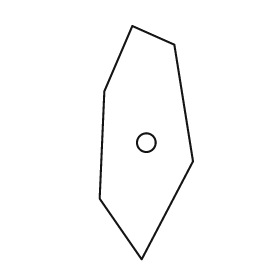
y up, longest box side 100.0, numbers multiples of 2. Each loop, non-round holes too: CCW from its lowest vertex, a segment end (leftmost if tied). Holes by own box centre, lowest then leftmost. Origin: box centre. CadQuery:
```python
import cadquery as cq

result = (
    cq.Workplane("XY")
    .moveTo(-2.0, -50.0)
    .lineTo(20.0, -8.0)
    .lineTo(12.0, 42.0)
    .lineTo(-6.0, 50.0)
    .lineTo(-18.0, 22.0)
    .lineTo(-20.0, -24.0)
    .close()
    .moveTo(0.0, 0.0)
    .circle(4.0)
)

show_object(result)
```